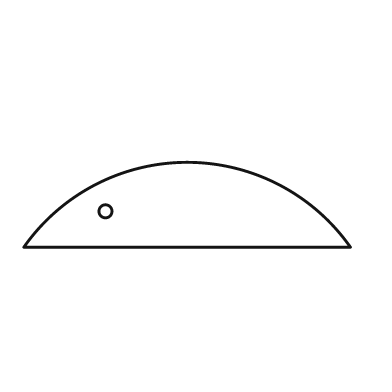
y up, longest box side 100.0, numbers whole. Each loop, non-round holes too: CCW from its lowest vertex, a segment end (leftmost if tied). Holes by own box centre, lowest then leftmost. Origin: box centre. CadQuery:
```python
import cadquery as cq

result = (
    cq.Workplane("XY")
    .moveTo(-50.0, -13.0)
    .lineTo(50.0, -13.0)
    .threePointArc((0.0, 13.0), (-50.0, -13.0))
    .close()
    .moveTo(-25.0, -2.0)
    .circle(2.0)
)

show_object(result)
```